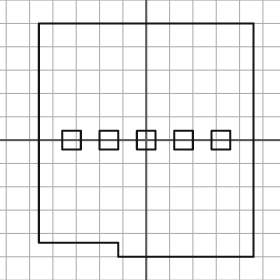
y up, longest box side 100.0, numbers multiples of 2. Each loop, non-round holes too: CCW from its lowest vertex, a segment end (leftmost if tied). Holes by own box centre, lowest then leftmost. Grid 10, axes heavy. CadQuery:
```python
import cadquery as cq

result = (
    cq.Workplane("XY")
    .moveTo(-12.0, -50.0)
    .lineTo(46.0, -50.0)
    .lineTo(46.0, 50.0)
    .lineTo(-46.0, 50.0)
    .lineTo(-46.0, -44.0)
    .lineTo(-12.0, -44.0)
    .close()
    .moveTo(-36.0, -4.0)
    .lineTo(-28.0, -4.0)
    .lineTo(-28.0, 4.0)
    .lineTo(-36.0, 4.0)
    .close()
    .moveTo(-20.0, -4.0)
    .lineTo(-12.0, -4.0)
    .lineTo(-12.0, 4.0)
    .lineTo(-20.0, 4.0)
    .close()
    .moveTo(-4.0, -4.0)
    .lineTo(4.0, -4.0)
    .lineTo(4.0, 4.0)
    .lineTo(-4.0, 4.0)
    .close()
    .moveTo(12.0, -4.0)
    .lineTo(20.0, -4.0)
    .lineTo(20.0, 4.0)
    .lineTo(12.0, 4.0)
    .close()
    .moveTo(28.0, -4.0)
    .lineTo(36.0, -4.0)
    .lineTo(36.0, 4.0)
    .lineTo(28.0, 4.0)
    .close()
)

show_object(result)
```